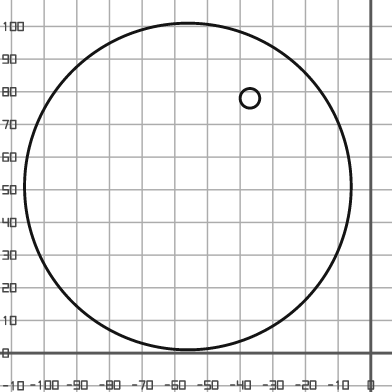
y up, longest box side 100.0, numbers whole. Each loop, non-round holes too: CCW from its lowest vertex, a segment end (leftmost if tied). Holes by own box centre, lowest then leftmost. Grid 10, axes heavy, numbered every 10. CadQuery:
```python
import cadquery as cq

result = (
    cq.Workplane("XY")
    .moveTo(-56.0, 51.0)
    .circle(50.0)
    .moveTo(-37.0, 78.0)
    .circle(3.0)
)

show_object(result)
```